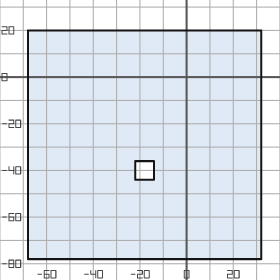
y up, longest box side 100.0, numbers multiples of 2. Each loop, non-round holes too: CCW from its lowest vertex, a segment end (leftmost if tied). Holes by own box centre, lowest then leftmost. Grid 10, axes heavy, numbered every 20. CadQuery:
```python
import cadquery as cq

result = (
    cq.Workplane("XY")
    .moveTo(-68.0, -78.0)
    .lineTo(32.0, -78.0)
    .lineTo(32.0, 20.0)
    .lineTo(-68.0, 20.0)
    .close()
    .moveTo(-22.0, -44.0)
    .lineTo(-14.0, -44.0)
    .lineTo(-14.0, -36.0)
    .lineTo(-22.0, -36.0)
    .close()
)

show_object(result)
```